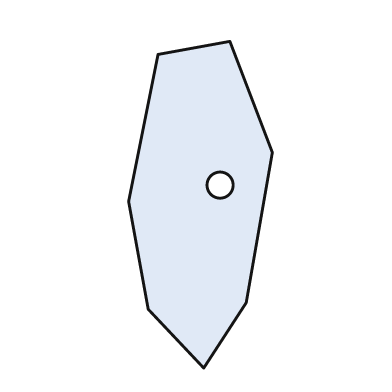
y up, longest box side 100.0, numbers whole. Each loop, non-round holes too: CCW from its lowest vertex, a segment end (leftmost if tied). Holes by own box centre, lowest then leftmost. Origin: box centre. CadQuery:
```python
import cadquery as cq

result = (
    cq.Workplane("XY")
    .moveTo(1.0, -50.0)
    .lineTo(14.0, -30.0)
    .lineTo(22.0, 16.0)
    .lineTo(9.0, 50.0)
    .lineTo(-13.0, 46.0)
    .lineTo(-22.0, 1.0)
    .lineTo(-16.0, -32.0)
    .close()
    .moveTo(6.0, 6.0)
    .circle(4.0)
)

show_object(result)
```